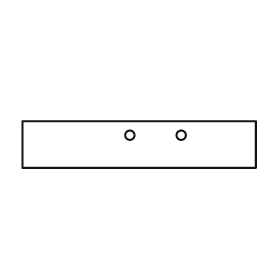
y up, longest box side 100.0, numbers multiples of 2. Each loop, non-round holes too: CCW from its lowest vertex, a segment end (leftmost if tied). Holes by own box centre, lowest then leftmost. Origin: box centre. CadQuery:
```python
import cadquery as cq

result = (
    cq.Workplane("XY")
    .moveTo(-50.0, -10.0)
    .lineTo(50.0, -10.0)
    .lineTo(50.0, 10.0)
    .lineTo(-50.0, 10.0)
    .close()
    .moveTo(-4.0, 4.0)
    .circle(2.0)
    .moveTo(18.0, 4.0)
    .circle(2.0)
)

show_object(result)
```